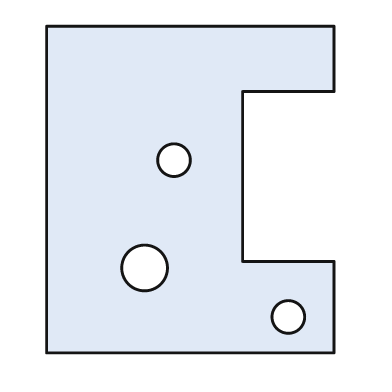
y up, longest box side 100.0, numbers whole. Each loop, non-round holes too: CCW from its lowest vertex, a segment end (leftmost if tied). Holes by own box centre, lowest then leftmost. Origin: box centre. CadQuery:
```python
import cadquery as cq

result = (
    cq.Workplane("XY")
    .moveTo(-44.0, -50.0)
    .lineTo(44.0, -50.0)
    .lineTo(44.0, -22.0)
    .lineTo(16.0, -22.0)
    .lineTo(16.0, 30.0)
    .lineTo(44.0, 30.0)
    .lineTo(44.0, 50.0)
    .lineTo(-44.0, 50.0)
    .close()
    .moveTo(30.0, -39.0)
    .circle(5.0)
    .moveTo(-14.0, -24.0)
    .circle(7.0)
    .moveTo(-5.0, 9.0)
    .circle(5.0)
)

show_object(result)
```